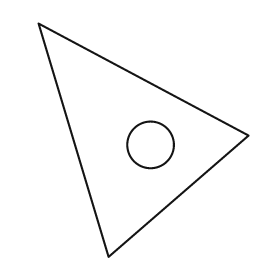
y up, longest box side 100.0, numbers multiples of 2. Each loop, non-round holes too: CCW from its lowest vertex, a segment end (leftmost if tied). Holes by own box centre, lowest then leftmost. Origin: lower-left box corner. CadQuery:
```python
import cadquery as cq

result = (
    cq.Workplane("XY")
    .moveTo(30.0, 0.0)
    .lineTo(90.0, 52.0)
    .lineTo(0.0, 100.0)
    .close()
    .moveTo(48.0, 48.0)
    .circle(10.0)
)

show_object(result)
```